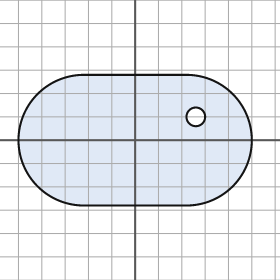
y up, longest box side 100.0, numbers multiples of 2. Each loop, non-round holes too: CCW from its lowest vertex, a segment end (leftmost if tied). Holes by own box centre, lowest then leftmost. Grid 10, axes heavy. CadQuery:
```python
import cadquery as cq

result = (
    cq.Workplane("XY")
    .moveTo(-22.0, -28.0)
    .lineTo(22.0, -28.0)
    .threePointArc((50.0, 0.0), (22.0, 28.0))
    .lineTo(-22.0, 28.0)
    .threePointArc((-50.0, 0.0), (-22.0, -28.0))
    .close()
    .moveTo(26.0, 10.0)
    .circle(4.0)
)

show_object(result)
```